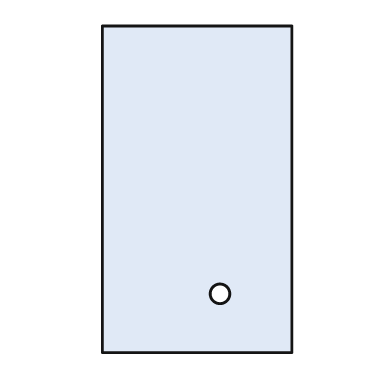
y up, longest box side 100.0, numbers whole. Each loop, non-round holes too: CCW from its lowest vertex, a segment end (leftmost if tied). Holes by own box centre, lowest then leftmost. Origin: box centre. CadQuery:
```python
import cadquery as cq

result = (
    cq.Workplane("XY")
    .moveTo(-29.0, -50.0)
    .lineTo(29.0, -50.0)
    .lineTo(29.0, 50.0)
    .lineTo(-29.0, 50.0)
    .close()
    .moveTo(7.0, -32.0)
    .circle(3.0)
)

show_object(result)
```